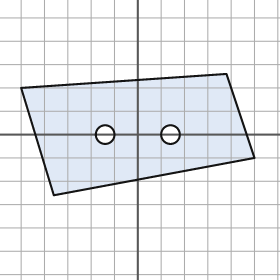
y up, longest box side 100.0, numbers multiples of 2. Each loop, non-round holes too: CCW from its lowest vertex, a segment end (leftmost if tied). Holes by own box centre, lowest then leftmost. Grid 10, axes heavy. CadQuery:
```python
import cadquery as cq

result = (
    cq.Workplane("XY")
    .moveTo(-36.0, -26.0)
    .lineTo(50.0, -10.0)
    .lineTo(38.0, 26.0)
    .lineTo(-50.0, 20.0)
    .close()
    .moveTo(-14.0, 0.0)
    .circle(4.0)
    .moveTo(14.0, 0.0)
    .circle(4.0)
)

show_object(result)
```